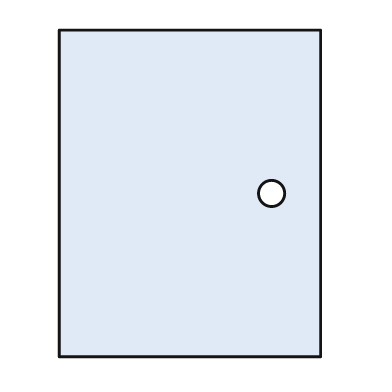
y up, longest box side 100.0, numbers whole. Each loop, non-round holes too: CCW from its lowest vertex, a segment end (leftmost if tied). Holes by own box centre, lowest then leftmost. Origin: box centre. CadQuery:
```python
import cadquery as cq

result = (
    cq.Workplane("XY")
    .moveTo(-40.0, -50.0)
    .lineTo(40.0, -50.0)
    .lineTo(40.0, 50.0)
    .lineTo(-40.0, 50.0)
    .close()
    .moveTo(25.0, 0.0)
    .circle(4.0)
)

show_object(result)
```